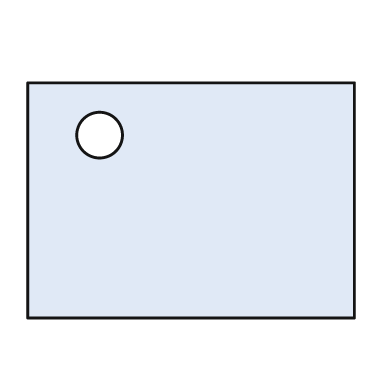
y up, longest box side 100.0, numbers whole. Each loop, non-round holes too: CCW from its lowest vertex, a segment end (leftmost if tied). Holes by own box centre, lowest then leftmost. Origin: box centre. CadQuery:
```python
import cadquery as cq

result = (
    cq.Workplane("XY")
    .moveTo(-50.0, -36.0)
    .lineTo(50.0, -36.0)
    .lineTo(50.0, 36.0)
    .lineTo(-50.0, 36.0)
    .close()
    .moveTo(-28.0, 20.0)
    .circle(7.0)
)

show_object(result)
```